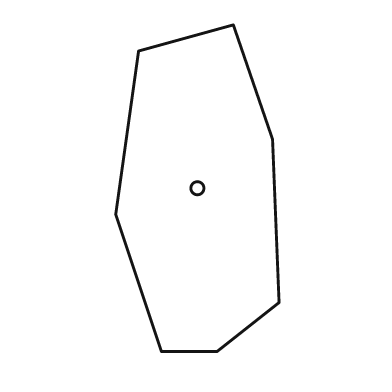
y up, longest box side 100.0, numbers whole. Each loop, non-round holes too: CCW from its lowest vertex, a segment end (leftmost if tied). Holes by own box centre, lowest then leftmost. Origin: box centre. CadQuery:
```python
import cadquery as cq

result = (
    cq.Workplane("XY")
    .moveTo(-11.0, -50.0)
    .lineTo(6.0, -50.0)
    .lineTo(25.0, -35.0)
    .lineTo(23.0, 15.0)
    .lineTo(11.0, 50.0)
    .lineTo(-18.0, 42.0)
    .lineTo(-25.0, -8.0)
    .close()
    .moveTo(0.0, 0.0)
    .circle(2.0)
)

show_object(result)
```